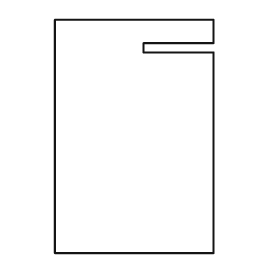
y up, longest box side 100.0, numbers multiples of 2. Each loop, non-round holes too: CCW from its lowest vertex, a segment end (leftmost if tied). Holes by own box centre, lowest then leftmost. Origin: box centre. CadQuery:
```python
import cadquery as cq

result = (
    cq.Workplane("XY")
    .moveTo(-34.0, -50.0)
    .lineTo(34.0, -50.0)
    .lineTo(34.0, 36.0)
    .lineTo(4.0, 36.0)
    .lineTo(4.0, 40.0)
    .lineTo(34.0, 40.0)
    .lineTo(34.0, 50.0)
    .lineTo(-34.0, 50.0)
    .close()
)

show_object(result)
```